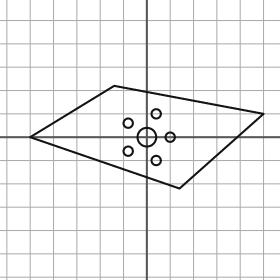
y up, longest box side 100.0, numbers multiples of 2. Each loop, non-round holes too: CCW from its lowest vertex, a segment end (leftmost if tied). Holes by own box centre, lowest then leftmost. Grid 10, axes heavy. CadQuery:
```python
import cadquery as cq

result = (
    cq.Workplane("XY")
    .moveTo(14.0, -22.0)
    .lineTo(50.0, 10.0)
    .lineTo(-14.0, 22.0)
    .lineTo(-50.0, 0.0)
    .close()
    .moveTo(4.0, -10.0)
    .circle(2.0)
    .moveTo(-8.0, -6.0)
    .circle(2.0)
    .moveTo(0.0, 0.0)
    .circle(4.0)
    .moveTo(10.0, 0.0)
    .circle(2.0)
    .moveTo(-8.0, 6.0)
    .circle(2.0)
    .moveTo(4.0, 10.0)
    .circle(2.0)
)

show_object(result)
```